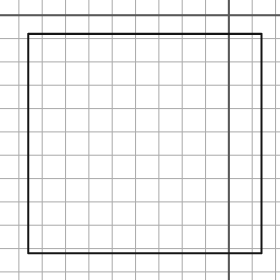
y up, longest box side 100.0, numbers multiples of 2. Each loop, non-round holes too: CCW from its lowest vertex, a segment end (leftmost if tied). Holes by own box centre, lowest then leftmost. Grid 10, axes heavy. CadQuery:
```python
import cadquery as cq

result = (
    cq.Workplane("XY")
    .moveTo(-86.0, -102.0)
    .lineTo(14.0, -102.0)
    .lineTo(14.0, -8.0)
    .lineTo(-86.0, -8.0)
    .close()
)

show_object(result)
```